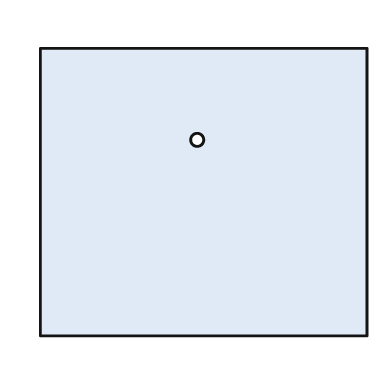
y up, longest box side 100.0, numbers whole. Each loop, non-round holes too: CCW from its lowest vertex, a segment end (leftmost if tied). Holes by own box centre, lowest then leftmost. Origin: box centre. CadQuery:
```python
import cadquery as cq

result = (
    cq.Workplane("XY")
    .moveTo(-50.0, -44.0)
    .lineTo(50.0, -44.0)
    .lineTo(50.0, 44.0)
    .lineTo(-50.0, 44.0)
    .close()
    .moveTo(-2.0, 16.0)
    .circle(2.0)
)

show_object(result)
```